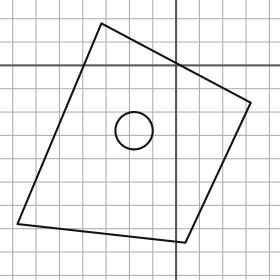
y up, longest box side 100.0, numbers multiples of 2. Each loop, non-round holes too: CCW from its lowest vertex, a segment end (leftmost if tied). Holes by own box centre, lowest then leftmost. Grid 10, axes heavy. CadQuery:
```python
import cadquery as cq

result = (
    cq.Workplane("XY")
    .moveTo(4.0, -76.0)
    .lineTo(32.0, -16.0)
    .lineTo(-32.0, 18.0)
    .lineTo(-68.0, -68.0)
    .close()
    .moveTo(-18.0, -28.0)
    .circle(8.0)
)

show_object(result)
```